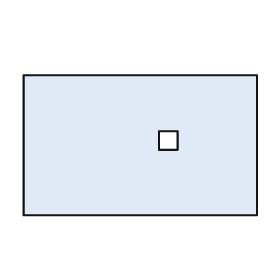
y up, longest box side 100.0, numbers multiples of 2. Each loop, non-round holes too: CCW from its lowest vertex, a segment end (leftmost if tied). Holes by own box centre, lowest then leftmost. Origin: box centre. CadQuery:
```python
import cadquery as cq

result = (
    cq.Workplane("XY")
    .moveTo(-50.0, -30.0)
    .lineTo(50.0, -30.0)
    .lineTo(50.0, 30.0)
    .lineTo(-50.0, 30.0)
    .close()
    .moveTo(8.0, -2.0)
    .lineTo(16.0, -2.0)
    .lineTo(16.0, 6.0)
    .lineTo(8.0, 6.0)
    .close()
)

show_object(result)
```